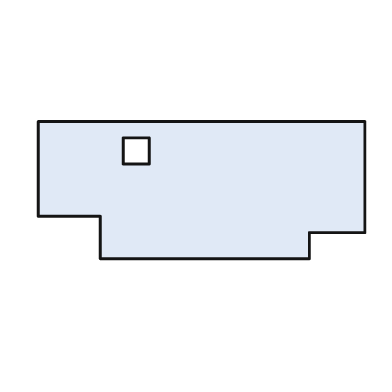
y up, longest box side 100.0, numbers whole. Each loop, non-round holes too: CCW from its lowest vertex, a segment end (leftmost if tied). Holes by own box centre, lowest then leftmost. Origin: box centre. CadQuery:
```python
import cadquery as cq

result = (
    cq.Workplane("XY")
    .moveTo(-31.0, -21.0)
    .lineTo(33.0, -21.0)
    .lineTo(33.0, -13.0)
    .lineTo(50.0, -13.0)
    .lineTo(50.0, 21.0)
    .lineTo(-50.0, 21.0)
    .lineTo(-50.0, -8.0)
    .lineTo(-31.0, -8.0)
    .close()
    .moveTo(-24.0, 8.0)
    .lineTo(-16.0, 8.0)
    .lineTo(-16.0, 16.0)
    .lineTo(-24.0, 16.0)
    .close()
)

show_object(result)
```